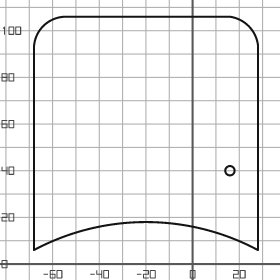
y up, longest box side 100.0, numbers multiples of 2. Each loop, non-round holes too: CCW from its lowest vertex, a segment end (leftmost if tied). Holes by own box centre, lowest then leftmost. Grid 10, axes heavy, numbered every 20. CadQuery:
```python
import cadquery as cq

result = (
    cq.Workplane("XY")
    .moveTo(-68.0, 6.0)
    .threePointArc((-20.0, 18.0), (28.0, 6.0))
    .lineTo(28.0, 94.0)
    .threePointArc((24.0, 102.0), (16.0, 106.0))
    .lineTo(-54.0, 106.0)
    .threePointArc((-64.0, 102.0), (-68.0, 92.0))
    .close()
    .moveTo(16.0, 40.0)
    .circle(2.0)
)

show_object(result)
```